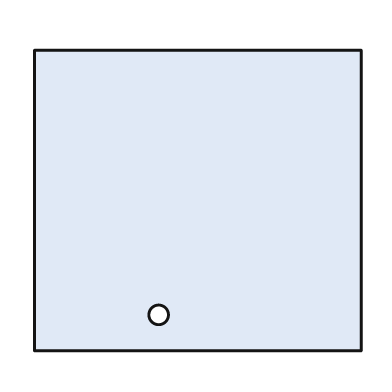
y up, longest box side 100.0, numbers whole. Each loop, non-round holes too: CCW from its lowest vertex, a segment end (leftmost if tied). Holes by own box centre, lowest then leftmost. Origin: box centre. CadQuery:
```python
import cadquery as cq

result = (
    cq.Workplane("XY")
    .moveTo(-50.0, -46.0)
    .lineTo(50.0, -46.0)
    .lineTo(50.0, 46.0)
    .lineTo(-50.0, 46.0)
    .close()
    .moveTo(-12.0, -35.0)
    .circle(3.0)
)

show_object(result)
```